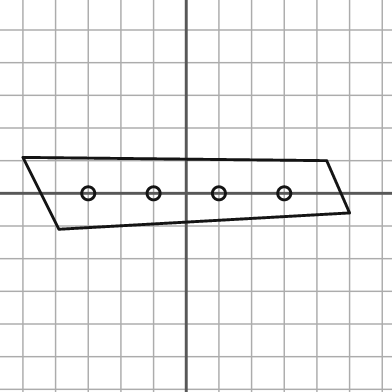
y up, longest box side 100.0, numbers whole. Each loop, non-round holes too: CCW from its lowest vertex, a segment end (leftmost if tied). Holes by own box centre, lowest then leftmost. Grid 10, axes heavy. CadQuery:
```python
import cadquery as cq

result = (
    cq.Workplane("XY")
    .moveTo(-39.0, -11.0)
    .lineTo(50.0, -6.0)
    .lineTo(43.0, 10.0)
    .lineTo(-50.0, 11.0)
    .close()
    .moveTo(-30.0, 0.0)
    .circle(2.0)
    .moveTo(-10.0, 0.0)
    .circle(2.0)
    .moveTo(10.0, 0.0)
    .circle(2.0)
    .moveTo(30.0, 0.0)
    .circle(2.0)
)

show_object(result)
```